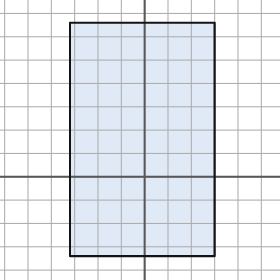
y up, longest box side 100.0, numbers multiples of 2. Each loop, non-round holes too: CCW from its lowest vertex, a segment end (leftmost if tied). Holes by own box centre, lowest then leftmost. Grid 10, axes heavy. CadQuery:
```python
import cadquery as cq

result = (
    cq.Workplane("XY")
    .moveTo(-32.0, -34.0)
    .lineTo(30.0, -34.0)
    .lineTo(30.0, 66.0)
    .lineTo(-32.0, 66.0)
    .close()
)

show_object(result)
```